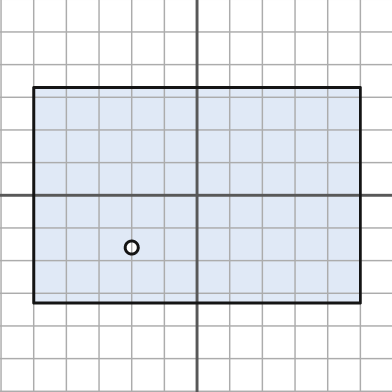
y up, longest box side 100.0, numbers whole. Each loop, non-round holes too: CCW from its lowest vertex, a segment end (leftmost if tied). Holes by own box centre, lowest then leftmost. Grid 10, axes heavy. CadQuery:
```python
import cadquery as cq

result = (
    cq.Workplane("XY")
    .moveTo(-50.0, -33.0)
    .lineTo(50.0, -33.0)
    .lineTo(50.0, 33.0)
    .lineTo(-50.0, 33.0)
    .close()
    .moveTo(-20.0, -16.0)
    .circle(2.0)
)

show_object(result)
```